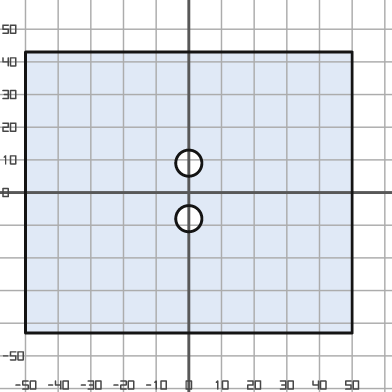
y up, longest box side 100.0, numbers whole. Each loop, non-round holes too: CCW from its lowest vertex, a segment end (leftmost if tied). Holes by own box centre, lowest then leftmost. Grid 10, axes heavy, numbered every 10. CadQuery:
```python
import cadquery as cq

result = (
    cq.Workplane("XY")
    .moveTo(-50.0, -43.0)
    .lineTo(50.0, -43.0)
    .lineTo(50.0, 43.0)
    .lineTo(-50.0, 43.0)
    .close()
    .moveTo(0.0, -8.0)
    .circle(4.0)
    .moveTo(0.0, 9.0)
    .circle(4.0)
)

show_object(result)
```